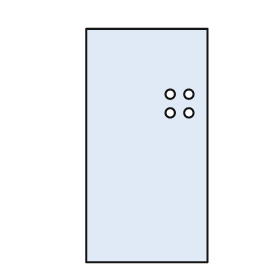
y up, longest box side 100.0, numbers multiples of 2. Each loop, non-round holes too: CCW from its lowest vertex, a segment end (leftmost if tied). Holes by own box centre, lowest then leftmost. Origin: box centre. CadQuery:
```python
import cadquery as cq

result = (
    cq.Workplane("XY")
    .moveTo(-26.0, -50.0)
    .lineTo(26.0, -50.0)
    .lineTo(26.0, 50.0)
    .lineTo(-26.0, 50.0)
    .close()
    .moveTo(10.0, 14.0)
    .circle(2.0)
    .moveTo(18.0, 14.0)
    .circle(2.0)
    .moveTo(10.0, 22.0)
    .circle(2.0)
    .moveTo(18.0, 22.0)
    .circle(2.0)
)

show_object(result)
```